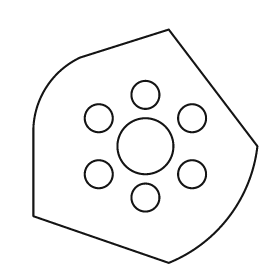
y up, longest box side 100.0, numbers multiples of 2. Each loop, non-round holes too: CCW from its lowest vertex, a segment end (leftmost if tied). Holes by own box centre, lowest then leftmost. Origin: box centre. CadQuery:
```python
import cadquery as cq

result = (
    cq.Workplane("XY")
    .moveTo(10.0, -50.0)
    .threePointArc((36.0, -30.0), (48.0, 0.0))
    .lineTo(10.0, 50.0)
    .lineTo(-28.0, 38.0)
    .threePointArc((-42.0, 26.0), (-48.0, 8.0))
    .lineTo(-48.0, -30.0)
    .close()
    .moveTo(0.0, -22.0)
    .circle(6.0)
    .moveTo(-20.0, -12.0)
    .circle(6.0)
    .moveTo(20.0, -12.0)
    .circle(6.0)
    .moveTo(0.0, 0.0)
    .circle(12.0)
    .moveTo(-20.0, 12.0)
    .circle(6.0)
    .moveTo(20.0, 12.0)
    .circle(6.0)
    .moveTo(0.0, 22.0)
    .circle(6.0)
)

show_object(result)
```